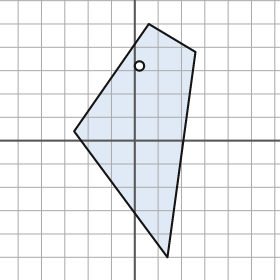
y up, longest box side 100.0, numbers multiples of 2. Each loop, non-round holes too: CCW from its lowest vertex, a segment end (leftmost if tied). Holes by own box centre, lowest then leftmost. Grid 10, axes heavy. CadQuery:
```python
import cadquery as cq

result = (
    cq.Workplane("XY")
    .moveTo(14.0, -50.0)
    .lineTo(26.0, 38.0)
    .lineTo(6.0, 50.0)
    .lineTo(-26.0, 4.0)
    .close()
    .moveTo(2.0, 32.0)
    .circle(2.0)
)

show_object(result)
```